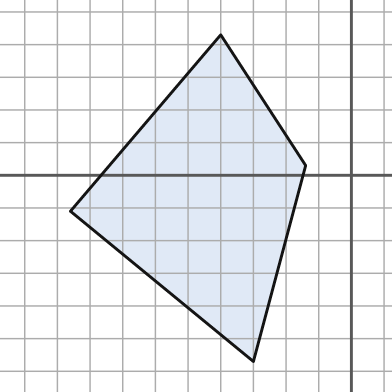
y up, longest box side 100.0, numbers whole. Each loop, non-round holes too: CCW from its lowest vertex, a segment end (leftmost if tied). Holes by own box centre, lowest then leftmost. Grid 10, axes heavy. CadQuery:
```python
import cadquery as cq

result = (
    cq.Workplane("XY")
    .moveTo(-30.0, -57.0)
    .lineTo(-14.0, 3.0)
    .lineTo(-40.0, 43.0)
    .lineTo(-86.0, -11.0)
    .close()
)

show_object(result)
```